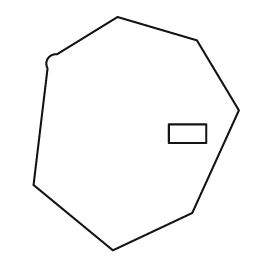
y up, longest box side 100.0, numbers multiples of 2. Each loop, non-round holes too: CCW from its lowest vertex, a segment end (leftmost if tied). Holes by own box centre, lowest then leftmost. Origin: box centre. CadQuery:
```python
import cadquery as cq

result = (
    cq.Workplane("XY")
    .moveTo(-10.0, -50.0)
    .lineTo(24.0, -34.0)
    .lineTo(44.0, 10.0)
    .lineTo(26.0, 40.0)
    .lineTo(-8.0, 50.0)
    .lineTo(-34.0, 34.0)
    .threePointArc((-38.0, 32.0), (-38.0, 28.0))
    .lineTo(-44.0, -22.0)
    .close()
    .moveTo(14.0, -4.0)
    .lineTo(30.0, -4.0)
    .lineTo(30.0, 4.0)
    .lineTo(14.0, 4.0)
    .close()
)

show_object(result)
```